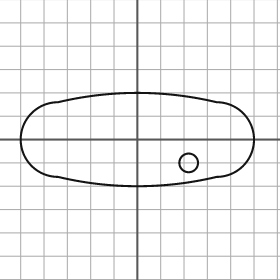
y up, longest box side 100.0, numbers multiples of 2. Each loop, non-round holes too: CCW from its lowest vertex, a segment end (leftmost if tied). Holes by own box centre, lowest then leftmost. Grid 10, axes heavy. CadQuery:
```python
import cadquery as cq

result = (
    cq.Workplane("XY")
    .moveTo(-34.0, -16.0)
    .threePointArc((0.0, -20.0), (34.0, -16.0))
    .threePointArc((50.0, 0.0), (34.0, 16.0))
    .threePointArc((0.0, 20.0), (-34.0, 16.0))
    .threePointArc((-50.0, 0.0), (-34.0, -16.0))
    .close()
    .moveTo(22.0, -10.0)
    .circle(4.0)
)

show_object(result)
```